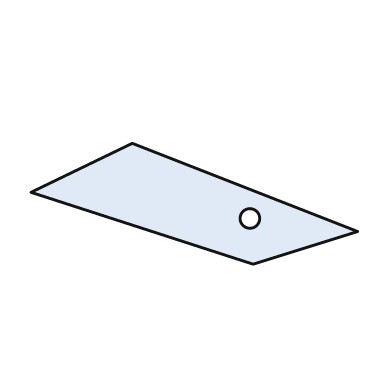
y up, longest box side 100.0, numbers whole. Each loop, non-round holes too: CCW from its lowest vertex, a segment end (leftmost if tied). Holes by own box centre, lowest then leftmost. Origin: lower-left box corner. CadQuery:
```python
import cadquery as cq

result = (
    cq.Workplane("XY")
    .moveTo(68.0, 0.0)
    .lineTo(100.0, 10.0)
    .lineTo(31.0, 37.0)
    .lineTo(0.0, 22.0)
    .close()
    .moveTo(67.0, 14.0)
    .circle(3.0)
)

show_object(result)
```